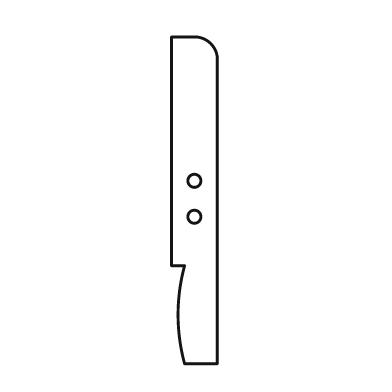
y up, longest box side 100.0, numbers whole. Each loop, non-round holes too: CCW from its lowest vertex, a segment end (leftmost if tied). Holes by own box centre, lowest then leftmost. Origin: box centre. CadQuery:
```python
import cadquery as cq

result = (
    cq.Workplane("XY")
    .moveTo(-3.0, -50.0)
    .lineTo(7.0, -50.0)
    .lineTo(7.0, 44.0)
    .threePointArc((5.0, 48.0), (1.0, 50.0))
    .lineTo(-7.0, 50.0)
    .lineTo(-7.0, -20.0)
    .lineTo(-3.0, -20.0)
    .threePointArc((-5.0, -35.0), (-3.0, -50.0))
    .close()
    .moveTo(0.0, -5.0)
    .circle(2.0)
    .moveTo(0.0, 6.0)
    .circle(2.0)
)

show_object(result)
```